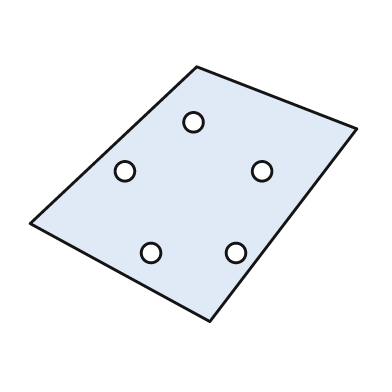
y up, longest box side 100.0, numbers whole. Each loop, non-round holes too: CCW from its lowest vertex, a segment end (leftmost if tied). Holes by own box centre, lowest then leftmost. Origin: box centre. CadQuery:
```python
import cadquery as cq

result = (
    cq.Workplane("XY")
    .moveTo(5.0, -39.0)
    .lineTo(50.0, 20.0)
    .lineTo(1.0, 39.0)
    .lineTo(-50.0, -9.0)
    .close()
    .moveTo(-13.0, -18.0)
    .circle(3.0)
    .moveTo(13.0, -18.0)
    .circle(3.0)
    .moveTo(-21.0, 7.0)
    .circle(3.0)
    .moveTo(21.0, 7.0)
    .circle(3.0)
    .moveTo(0.0, 22.0)
    .circle(3.0)
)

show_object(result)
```